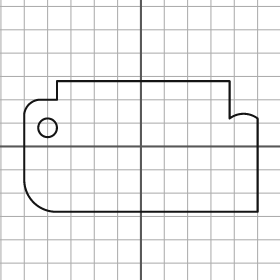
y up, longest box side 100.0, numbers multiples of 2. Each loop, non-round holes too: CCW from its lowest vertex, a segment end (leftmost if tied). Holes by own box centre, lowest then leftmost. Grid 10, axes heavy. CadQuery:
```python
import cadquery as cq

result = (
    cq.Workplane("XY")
    .moveTo(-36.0, -28.0)
    .lineTo(50.0, -28.0)
    .lineTo(50.0, 12.0)
    .threePointArc((44.0, 14.0), (38.0, 12.0))
    .lineTo(38.0, 28.0)
    .lineTo(-36.0, 28.0)
    .lineTo(-36.0, 20.0)
    .lineTo(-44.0, 20.0)
    .threePointArc((-48.0, 18.0), (-50.0, 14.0))
    .lineTo(-50.0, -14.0)
    .threePointArc((-46.0, -24.0), (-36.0, -28.0))
    .close()
    .moveTo(-40.0, 8.0)
    .circle(4.0)
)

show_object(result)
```